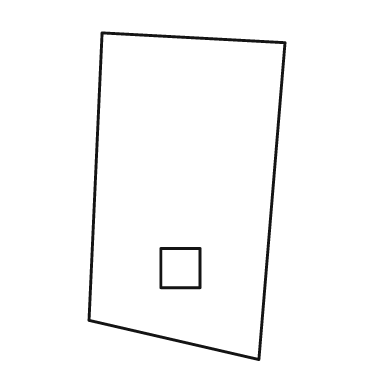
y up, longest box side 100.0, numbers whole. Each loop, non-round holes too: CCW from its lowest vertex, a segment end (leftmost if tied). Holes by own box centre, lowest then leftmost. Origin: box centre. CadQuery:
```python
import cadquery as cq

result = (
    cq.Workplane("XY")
    .moveTo(22.0, -50.0)
    .lineTo(30.0, 47.0)
    .lineTo(-26.0, 50.0)
    .lineTo(-30.0, -38.0)
    .close()
    .moveTo(-8.0, -28.0)
    .lineTo(4.0, -28.0)
    .lineTo(4.0, -16.0)
    .lineTo(-8.0, -16.0)
    .close()
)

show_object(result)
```